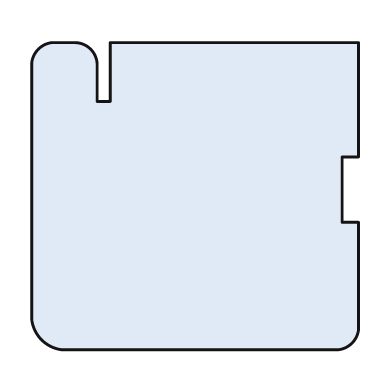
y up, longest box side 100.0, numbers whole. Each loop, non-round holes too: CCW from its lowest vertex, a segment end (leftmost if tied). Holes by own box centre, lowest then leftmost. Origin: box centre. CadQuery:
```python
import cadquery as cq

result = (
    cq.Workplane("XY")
    .moveTo(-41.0, -47.0)
    .lineTo(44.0, -47.0)
    .threePointArc((48.0, -45.0), (50.0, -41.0))
    .lineTo(50.0, -8.0)
    .lineTo(45.0, -8.0)
    .lineTo(45.0, 12.0)
    .lineTo(50.0, 12.0)
    .lineTo(50.0, 47.0)
    .lineTo(-26.0, 47.0)
    .lineTo(-26.0, 29.0)
    .lineTo(-30.0, 29.0)
    .lineTo(-30.0, 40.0)
    .threePointArc((-32.0, 45.0), (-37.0, 47.0))
    .lineTo(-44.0, 47.0)
    .threePointArc((-48.0, 45.0), (-50.0, 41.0))
    .lineTo(-50.0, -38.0)
    .threePointArc((-47.0, -44.0), (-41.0, -47.0))
    .close()
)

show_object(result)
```